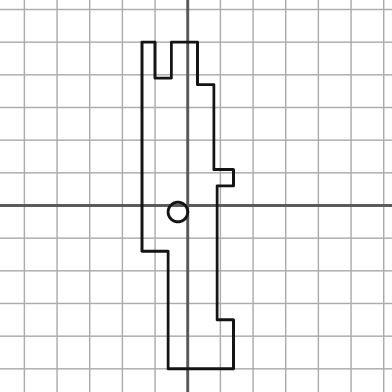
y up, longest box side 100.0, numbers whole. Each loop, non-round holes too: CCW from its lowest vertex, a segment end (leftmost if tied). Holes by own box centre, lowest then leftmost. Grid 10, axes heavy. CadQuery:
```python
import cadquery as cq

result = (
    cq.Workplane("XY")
    .moveTo(-6.0, -50.0)
    .lineTo(14.0, -50.0)
    .lineTo(14.0, -35.0)
    .lineTo(9.0, -35.0)
    .lineTo(9.0, 6.0)
    .lineTo(14.0, 6.0)
    .lineTo(14.0, 11.0)
    .lineTo(8.0, 11.0)
    .lineTo(8.0, 37.0)
    .lineTo(3.0, 37.0)
    .lineTo(3.0, 50.0)
    .lineTo(-5.0, 50.0)
    .lineTo(-5.0, 39.0)
    .lineTo(-10.0, 39.0)
    .lineTo(-10.0, 50.0)
    .lineTo(-14.0, 50.0)
    .lineTo(-14.0, -14.0)
    .lineTo(-6.0, -14.0)
    .close()
    .moveTo(-3.0, -2.0)
    .circle(3.0)
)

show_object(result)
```